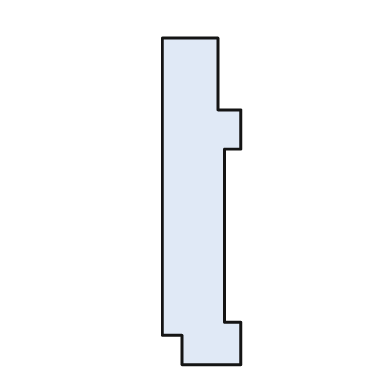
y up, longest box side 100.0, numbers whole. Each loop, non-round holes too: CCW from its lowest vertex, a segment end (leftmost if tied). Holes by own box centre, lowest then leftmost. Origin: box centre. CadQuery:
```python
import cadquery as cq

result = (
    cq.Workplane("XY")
    .moveTo(-6.0, -50.0)
    .lineTo(12.0, -50.0)
    .lineTo(12.0, -37.0)
    .lineTo(7.0, -37.0)
    .lineTo(7.0, 16.0)
    .lineTo(12.0, 16.0)
    .lineTo(12.0, 28.0)
    .lineTo(5.0, 28.0)
    .lineTo(5.0, 50.0)
    .lineTo(-12.0, 50.0)
    .lineTo(-12.0, -41.0)
    .lineTo(-6.0, -41.0)
    .close()
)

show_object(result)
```